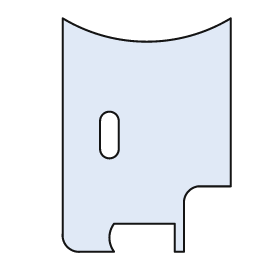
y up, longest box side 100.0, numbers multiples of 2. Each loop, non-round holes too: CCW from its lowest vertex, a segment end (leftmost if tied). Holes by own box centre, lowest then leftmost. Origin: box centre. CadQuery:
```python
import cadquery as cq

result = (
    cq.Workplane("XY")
    .moveTo(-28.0, -50.0)
    .lineTo(-14.0, -50.0)
    .threePointArc((-16.0, -44.0), (-14.0, -38.0))
    .lineTo(12.0, -38.0)
    .lineTo(12.0, -50.0)
    .lineTo(16.0, -50.0)
    .lineTo(16.0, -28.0)
    .threePointArc((18.0, -24.0), (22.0, -22.0))
    .lineTo(36.0, -22.0)
    .lineTo(36.0, 50.0)
    .threePointArc((0.0, 40.0), (-36.0, 50.0))
    .lineTo(-36.0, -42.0)
    .threePointArc((-34.0, -48.0), (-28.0, -50.0))
    .close()
    .moveTo(-20.0, -6.0)
    .threePointArc((-16.0, -10.0), (-12.0, -6.0))
    .lineTo(-12.0, 6.0)
    .threePointArc((-16.0, 10.0), (-20.0, 6.0))
    .close()
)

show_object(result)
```